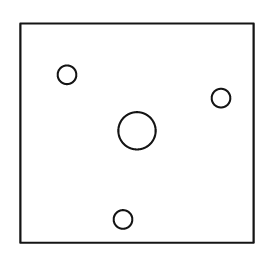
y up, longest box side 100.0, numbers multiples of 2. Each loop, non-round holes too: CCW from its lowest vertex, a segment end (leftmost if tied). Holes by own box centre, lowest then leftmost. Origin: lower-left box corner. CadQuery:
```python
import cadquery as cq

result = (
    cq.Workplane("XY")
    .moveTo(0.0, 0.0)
    .lineTo(100.0, 0.0)
    .lineTo(100.0, 94.0)
    .lineTo(0.0, 94.0)
    .close()
    .moveTo(44.0, 10.0)
    .circle(4.0)
    .moveTo(50.0, 48.0)
    .circle(8.0)
    .moveTo(86.0, 62.0)
    .circle(4.0)
    .moveTo(20.0, 72.0)
    .circle(4.0)
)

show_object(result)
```